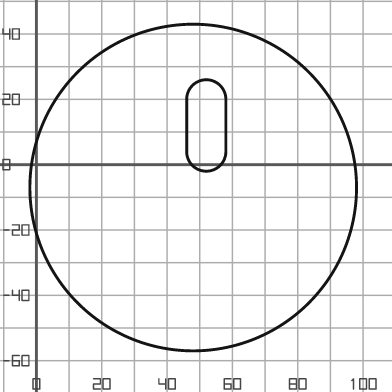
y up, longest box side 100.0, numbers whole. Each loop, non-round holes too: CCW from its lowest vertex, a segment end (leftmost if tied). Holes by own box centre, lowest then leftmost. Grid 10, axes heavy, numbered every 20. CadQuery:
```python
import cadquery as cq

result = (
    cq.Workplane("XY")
    .moveTo(48.0, -7.0)
    .circle(50.0)
    .moveTo(46.0, 4.0)
    .threePointArc((52.0, -2.0), (58.0, 4.0))
    .lineTo(58.0, 20.0)
    .threePointArc((52.0, 26.0), (46.0, 20.0))
    .close()
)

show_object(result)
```